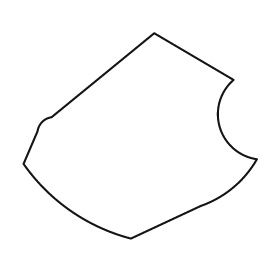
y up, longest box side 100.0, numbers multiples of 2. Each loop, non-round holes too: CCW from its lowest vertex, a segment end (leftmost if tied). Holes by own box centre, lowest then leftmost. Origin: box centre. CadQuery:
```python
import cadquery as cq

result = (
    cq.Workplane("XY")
    .moveTo(-4.0, -44.0)
    .lineTo(26.0, -30.0)
    .threePointArc((40.0, -22.0), (50.0, -10.0))
    .threePointArc((34.0, 4.0), (40.0, 24.0))
    .lineTo(6.0, 44.0)
    .lineTo(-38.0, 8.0)
    .threePointArc((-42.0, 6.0), (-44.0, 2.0))
    .lineTo(-50.0, -12.0)
    .threePointArc((-30.0, -32.0), (-4.0, -44.0))
    .close()
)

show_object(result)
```